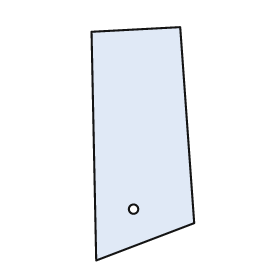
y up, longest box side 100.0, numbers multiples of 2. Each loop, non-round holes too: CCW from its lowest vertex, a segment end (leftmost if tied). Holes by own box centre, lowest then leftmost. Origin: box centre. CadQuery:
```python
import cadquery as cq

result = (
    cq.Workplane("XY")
    .moveTo(-20.0, -50.0)
    .lineTo(22.0, -34.0)
    .lineTo(16.0, 50.0)
    .lineTo(-22.0, 48.0)
    .close()
    .moveTo(-4.0, -28.0)
    .circle(2.0)
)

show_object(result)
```